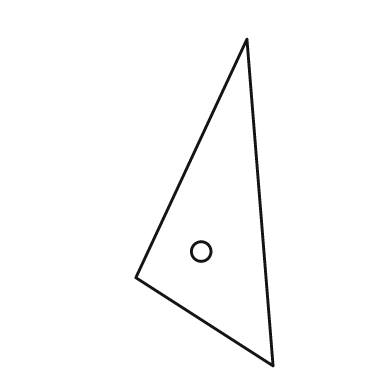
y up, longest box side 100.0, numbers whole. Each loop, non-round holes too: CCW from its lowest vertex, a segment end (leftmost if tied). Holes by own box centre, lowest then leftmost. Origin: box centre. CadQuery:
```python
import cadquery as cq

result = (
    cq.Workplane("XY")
    .moveTo(21.0, -50.0)
    .lineTo(13.0, 50.0)
    .lineTo(-21.0, -23.0)
    .close()
    .moveTo(-1.0, -15.0)
    .circle(3.0)
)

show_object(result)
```